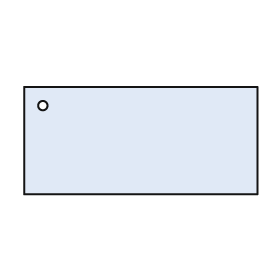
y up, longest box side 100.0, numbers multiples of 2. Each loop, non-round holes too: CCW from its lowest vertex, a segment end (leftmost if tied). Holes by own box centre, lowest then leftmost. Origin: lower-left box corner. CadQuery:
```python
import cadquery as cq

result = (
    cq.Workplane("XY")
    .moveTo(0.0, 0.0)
    .lineTo(100.0, 0.0)
    .lineTo(100.0, 46.0)
    .lineTo(0.0, 46.0)
    .close()
    .moveTo(8.0, 38.0)
    .circle(2.0)
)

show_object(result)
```